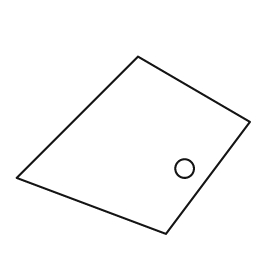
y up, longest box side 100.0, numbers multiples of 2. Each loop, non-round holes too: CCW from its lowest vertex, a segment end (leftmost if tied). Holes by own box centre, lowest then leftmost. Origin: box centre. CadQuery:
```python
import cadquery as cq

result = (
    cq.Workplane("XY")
    .moveTo(14.0, -38.0)
    .lineTo(50.0, 10.0)
    .lineTo(2.0, 38.0)
    .lineTo(-50.0, -14.0)
    .close()
    .moveTo(22.0, -10.0)
    .circle(4.0)
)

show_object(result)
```